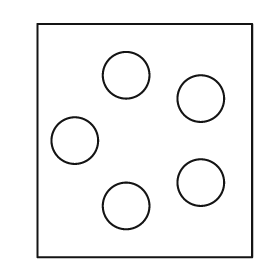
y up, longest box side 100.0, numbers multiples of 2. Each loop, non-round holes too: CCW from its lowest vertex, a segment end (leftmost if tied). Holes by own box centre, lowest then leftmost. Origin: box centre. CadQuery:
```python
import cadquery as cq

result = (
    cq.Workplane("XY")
    .moveTo(-46.0, -50.0)
    .lineTo(46.0, -50.0)
    .lineTo(46.0, 50.0)
    .lineTo(-46.0, 50.0)
    .close()
    .moveTo(-8.0, -28.0)
    .circle(10.0)
    .moveTo(24.0, -18.0)
    .circle(10.0)
    .moveTo(-30.0, 0.0)
    .circle(10.0)
    .moveTo(24.0, 18.0)
    .circle(10.0)
    .moveTo(-8.0, 28.0)
    .circle(10.0)
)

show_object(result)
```